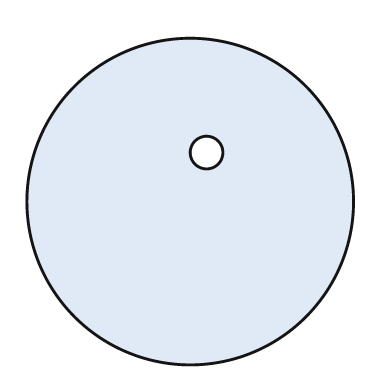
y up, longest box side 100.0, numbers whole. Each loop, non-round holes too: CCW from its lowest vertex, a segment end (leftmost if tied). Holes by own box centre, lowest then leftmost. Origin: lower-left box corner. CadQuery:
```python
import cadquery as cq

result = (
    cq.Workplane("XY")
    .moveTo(50.0, 50.0)
    .circle(50.0)
    .moveTo(55.0, 65.0)
    .circle(5.0)
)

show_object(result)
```